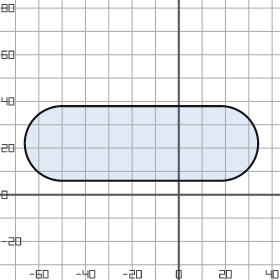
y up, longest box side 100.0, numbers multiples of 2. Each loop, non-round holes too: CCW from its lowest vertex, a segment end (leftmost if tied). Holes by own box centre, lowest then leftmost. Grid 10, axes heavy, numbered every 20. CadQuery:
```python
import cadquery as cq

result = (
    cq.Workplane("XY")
    .moveTo(-50.0, 6.0)
    .lineTo(18.0, 6.0)
    .threePointArc((34.0, 22.0), (18.0, 38.0))
    .lineTo(-50.0, 38.0)
    .threePointArc((-66.0, 22.0), (-50.0, 6.0))
    .close()
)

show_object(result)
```